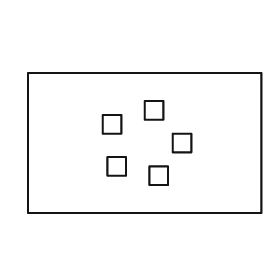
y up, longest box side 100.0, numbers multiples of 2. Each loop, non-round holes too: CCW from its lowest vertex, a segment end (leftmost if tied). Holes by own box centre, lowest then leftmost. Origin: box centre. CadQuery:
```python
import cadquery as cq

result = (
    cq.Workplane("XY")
    .moveTo(-50.0, -30.0)
    .lineTo(50.0, -30.0)
    .lineTo(50.0, 30.0)
    .lineTo(-50.0, 30.0)
    .close()
    .moveTo(2.0, -18.0)
    .lineTo(10.0, -18.0)
    .lineTo(10.0, -10.0)
    .lineTo(2.0, -10.0)
    .close()
    .moveTo(-16.0, -14.0)
    .lineTo(-8.0, -14.0)
    .lineTo(-8.0, -6.0)
    .lineTo(-16.0, -6.0)
    .close()
    .moveTo(12.0, -4.0)
    .lineTo(20.0, -4.0)
    .lineTo(20.0, 4.0)
    .lineTo(12.0, 4.0)
    .close()
    .moveTo(-18.0, 4.0)
    .lineTo(-10.0, 4.0)
    .lineTo(-10.0, 12.0)
    .lineTo(-18.0, 12.0)
    .close()
    .moveTo(0.0, 10.0)
    .lineTo(8.0, 10.0)
    .lineTo(8.0, 18.0)
    .lineTo(0.0, 18.0)
    .close()
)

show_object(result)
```